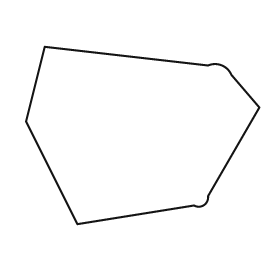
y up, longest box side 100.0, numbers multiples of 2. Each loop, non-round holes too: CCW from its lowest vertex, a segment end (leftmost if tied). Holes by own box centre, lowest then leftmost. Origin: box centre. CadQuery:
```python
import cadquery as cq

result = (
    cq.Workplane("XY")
    .moveTo(-28.0, -38.0)
    .lineTo(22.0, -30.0)
    .threePointArc((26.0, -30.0), (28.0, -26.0))
    .lineTo(50.0, 12.0)
    .lineTo(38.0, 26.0)
    .threePointArc((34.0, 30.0), (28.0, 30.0))
    .lineTo(-42.0, 38.0)
    .lineTo(-50.0, 6.0)
    .close()
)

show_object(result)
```